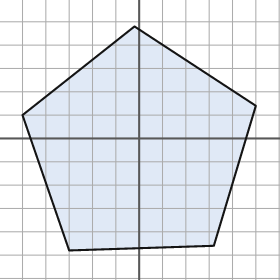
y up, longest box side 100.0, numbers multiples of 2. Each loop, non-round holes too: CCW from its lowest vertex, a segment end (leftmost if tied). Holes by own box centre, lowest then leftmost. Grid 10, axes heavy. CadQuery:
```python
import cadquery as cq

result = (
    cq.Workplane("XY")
    .moveTo(-30.0, -48.0)
    .lineTo(32.0, -46.0)
    .lineTo(50.0, 14.0)
    .lineTo(-2.0, 48.0)
    .lineTo(-50.0, 10.0)
    .close()
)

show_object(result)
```